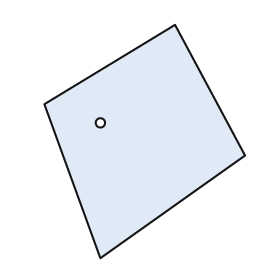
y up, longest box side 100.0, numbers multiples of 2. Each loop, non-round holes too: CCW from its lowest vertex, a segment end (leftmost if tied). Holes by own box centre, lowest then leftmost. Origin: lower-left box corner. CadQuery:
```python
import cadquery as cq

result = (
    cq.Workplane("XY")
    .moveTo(24.0, 0.0)
    .lineTo(86.0, 44.0)
    .lineTo(56.0, 100.0)
    .lineTo(0.0, 66.0)
    .close()
    .moveTo(24.0, 58.0)
    .circle(2.0)
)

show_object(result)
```